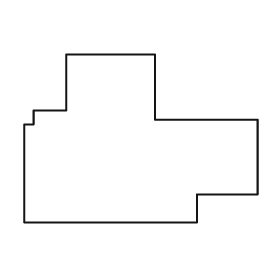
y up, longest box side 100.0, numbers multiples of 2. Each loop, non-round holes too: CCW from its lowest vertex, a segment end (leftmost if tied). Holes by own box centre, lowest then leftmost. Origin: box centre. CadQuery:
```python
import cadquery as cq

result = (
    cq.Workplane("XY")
    .moveTo(-50.0, -36.0)
    .lineTo(24.0, -36.0)
    .lineTo(24.0, -24.0)
    .lineTo(50.0, -24.0)
    .lineTo(50.0, 8.0)
    .lineTo(6.0, 8.0)
    .lineTo(6.0, 36.0)
    .lineTo(-32.0, 36.0)
    .lineTo(-32.0, 12.0)
    .lineTo(-46.0, 12.0)
    .lineTo(-46.0, 6.0)
    .lineTo(-50.0, 6.0)
    .close()
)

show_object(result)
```